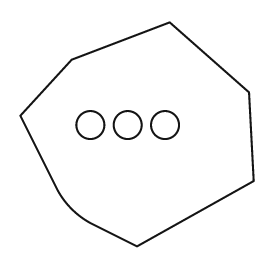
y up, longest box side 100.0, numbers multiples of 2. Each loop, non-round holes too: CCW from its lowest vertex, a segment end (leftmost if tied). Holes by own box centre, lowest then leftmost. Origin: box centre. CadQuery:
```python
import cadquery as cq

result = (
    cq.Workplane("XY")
    .moveTo(0.0, -48.0)
    .lineTo(50.0, -20.0)
    .lineTo(48.0, 18.0)
    .lineTo(14.0, 48.0)
    .lineTo(-28.0, 32.0)
    .lineTo(-50.0, 8.0)
    .lineTo(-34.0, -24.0)
    .threePointArc((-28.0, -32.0), (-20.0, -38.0))
    .close()
    .moveTo(-20.0, 4.0)
    .circle(6.0)
    .moveTo(-4.0, 4.0)
    .circle(6.0)
    .moveTo(12.0, 4.0)
    .circle(6.0)
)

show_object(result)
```